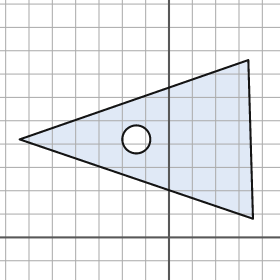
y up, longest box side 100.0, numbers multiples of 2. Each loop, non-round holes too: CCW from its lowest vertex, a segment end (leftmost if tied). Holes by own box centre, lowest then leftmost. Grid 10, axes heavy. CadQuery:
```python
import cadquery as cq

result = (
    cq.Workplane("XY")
    .moveTo(36.0, 8.0)
    .lineTo(34.0, 76.0)
    .lineTo(-64.0, 42.0)
    .close()
    .moveTo(-14.0, 42.0)
    .circle(6.0)
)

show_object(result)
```